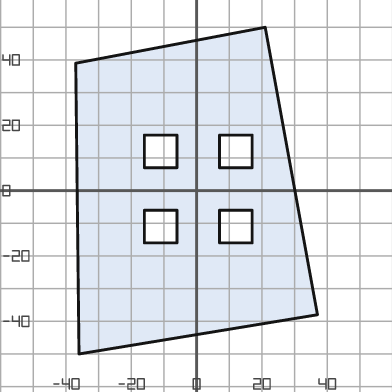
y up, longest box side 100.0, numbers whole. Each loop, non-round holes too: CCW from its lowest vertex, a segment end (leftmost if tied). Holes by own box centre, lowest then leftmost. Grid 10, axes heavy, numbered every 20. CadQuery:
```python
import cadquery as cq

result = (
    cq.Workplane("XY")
    .moveTo(-36.0, -50.0)
    .lineTo(37.0, -38.0)
    .lineTo(21.0, 50.0)
    .lineTo(-37.0, 39.0)
    .close()
    .moveTo(-16.0, -16.0)
    .lineTo(-6.0, -16.0)
    .lineTo(-6.0, -6.0)
    .lineTo(-16.0, -6.0)
    .close()
    .moveTo(7.0, -16.0)
    .lineTo(17.0, -16.0)
    .lineTo(17.0, -6.0)
    .lineTo(7.0, -6.0)
    .close()
    .moveTo(-16.0, 7.0)
    .lineTo(-6.0, 7.0)
    .lineTo(-6.0, 17.0)
    .lineTo(-16.0, 17.0)
    .close()
    .moveTo(7.0, 7.0)
    .lineTo(17.0, 7.0)
    .lineTo(17.0, 17.0)
    .lineTo(7.0, 17.0)
    .close()
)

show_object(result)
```